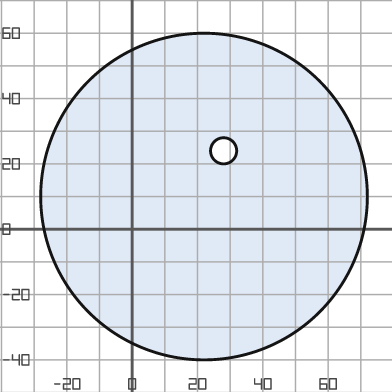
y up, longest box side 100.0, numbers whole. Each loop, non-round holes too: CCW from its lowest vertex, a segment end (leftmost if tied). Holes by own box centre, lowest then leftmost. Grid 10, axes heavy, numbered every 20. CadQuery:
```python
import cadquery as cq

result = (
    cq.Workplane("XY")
    .moveTo(22.0, 10.0)
    .circle(50.0)
    .moveTo(28.0, 24.0)
    .circle(4.0)
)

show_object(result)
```